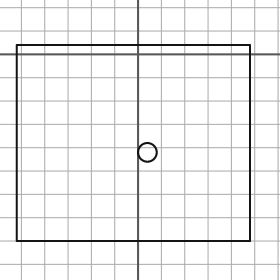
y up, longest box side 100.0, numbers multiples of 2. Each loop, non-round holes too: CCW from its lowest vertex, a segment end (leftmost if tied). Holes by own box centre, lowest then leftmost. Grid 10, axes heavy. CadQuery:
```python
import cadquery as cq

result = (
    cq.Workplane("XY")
    .moveTo(-52.0, -80.0)
    .lineTo(48.0, -80.0)
    .lineTo(48.0, 4.0)
    .lineTo(-52.0, 4.0)
    .close()
    .moveTo(4.0, -42.0)
    .circle(4.0)
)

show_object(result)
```